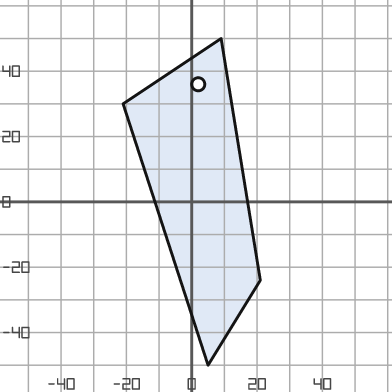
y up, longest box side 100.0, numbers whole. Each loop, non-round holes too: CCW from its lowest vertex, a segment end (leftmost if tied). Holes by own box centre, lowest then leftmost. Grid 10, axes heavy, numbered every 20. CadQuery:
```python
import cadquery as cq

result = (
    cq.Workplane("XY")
    .moveTo(5.0, -50.0)
    .lineTo(21.0, -24.0)
    .lineTo(9.0, 50.0)
    .lineTo(-21.0, 30.0)
    .close()
    .moveTo(2.0, 36.0)
    .circle(2.0)
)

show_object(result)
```